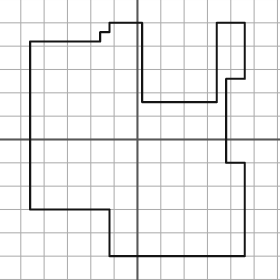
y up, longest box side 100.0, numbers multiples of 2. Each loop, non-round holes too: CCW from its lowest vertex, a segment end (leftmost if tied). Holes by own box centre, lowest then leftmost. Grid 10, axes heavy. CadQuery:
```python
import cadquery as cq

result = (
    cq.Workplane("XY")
    .moveTo(-12.0, -50.0)
    .lineTo(46.0, -50.0)
    .lineTo(46.0, -10.0)
    .lineTo(38.0, -10.0)
    .lineTo(38.0, 26.0)
    .lineTo(46.0, 26.0)
    .lineTo(46.0, 50.0)
    .lineTo(34.0, 50.0)
    .lineTo(34.0, 16.0)
    .lineTo(2.0, 16.0)
    .lineTo(2.0, 50.0)
    .lineTo(-12.0, 50.0)
    .lineTo(-12.0, 46.0)
    .lineTo(-16.0, 46.0)
    .lineTo(-16.0, 42.0)
    .lineTo(-46.0, 42.0)
    .lineTo(-46.0, -30.0)
    .lineTo(-12.0, -30.0)
    .close()
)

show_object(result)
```